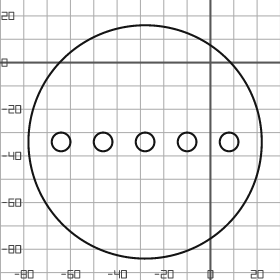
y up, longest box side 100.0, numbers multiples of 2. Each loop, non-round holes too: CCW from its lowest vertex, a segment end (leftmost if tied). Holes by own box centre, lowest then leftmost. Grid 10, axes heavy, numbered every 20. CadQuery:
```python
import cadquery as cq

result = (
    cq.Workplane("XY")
    .moveTo(-28.0, -34.0)
    .circle(50.0)
    .moveTo(-64.0, -34.0)
    .circle(4.0)
    .moveTo(-46.0, -34.0)
    .circle(4.0)
    .moveTo(-28.0, -34.0)
    .circle(4.0)
    .moveTo(-10.0, -34.0)
    .circle(4.0)
    .moveTo(8.0, -34.0)
    .circle(4.0)
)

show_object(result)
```